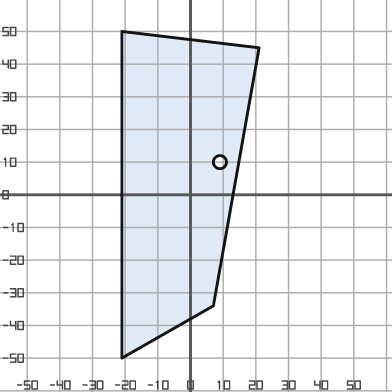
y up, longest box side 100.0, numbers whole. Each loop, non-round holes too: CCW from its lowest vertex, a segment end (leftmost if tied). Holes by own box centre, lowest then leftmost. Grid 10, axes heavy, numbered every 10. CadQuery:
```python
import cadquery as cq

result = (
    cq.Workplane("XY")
    .moveTo(-21.0, -50.0)
    .lineTo(7.0, -34.0)
    .lineTo(21.0, 45.0)
    .lineTo(-21.0, 50.0)
    .close()
    .moveTo(9.0, 10.0)
    .circle(2.0)
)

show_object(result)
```